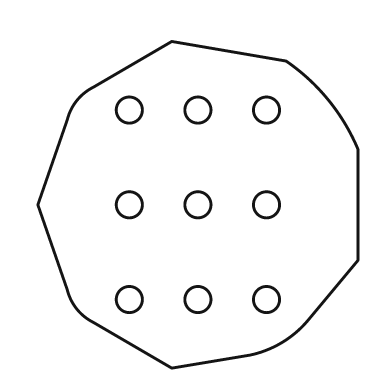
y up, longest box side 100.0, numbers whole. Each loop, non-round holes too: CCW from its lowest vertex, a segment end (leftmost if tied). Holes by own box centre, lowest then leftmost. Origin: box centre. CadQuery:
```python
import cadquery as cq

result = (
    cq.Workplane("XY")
    .moveTo(-8.0, -50.0)
    .lineTo(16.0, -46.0)
    .threePointArc((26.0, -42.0), (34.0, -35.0))
    .lineTo(49.0, -17.0)
    .lineTo(49.0, 17.0)
    .threePointArc((40.0, 32.0), (27.0, 44.0))
    .lineTo(-8.0, 50.0)
    .lineTo(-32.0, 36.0)
    .threePointArc((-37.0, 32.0), (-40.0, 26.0))
    .lineTo(-49.0, 0.0)
    .lineTo(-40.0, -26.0)
    .threePointArc((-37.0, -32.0), (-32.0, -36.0))
    .close()
    .moveTo(-21.0, -29.0)
    .circle(4.0)
    .moveTo(0.0, -29.0)
    .circle(4.0)
    .moveTo(21.0, -29.0)
    .circle(4.0)
    .moveTo(-21.0, 0.0)
    .circle(4.0)
    .moveTo(0.0, 0.0)
    .circle(4.0)
    .moveTo(21.0, 0.0)
    .circle(4.0)
    .moveTo(-21.0, 29.0)
    .circle(4.0)
    .moveTo(0.0, 29.0)
    .circle(4.0)
    .moveTo(21.0, 29.0)
    .circle(4.0)
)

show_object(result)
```